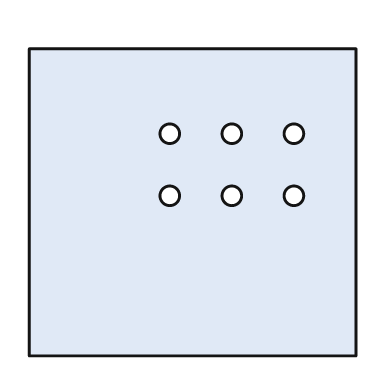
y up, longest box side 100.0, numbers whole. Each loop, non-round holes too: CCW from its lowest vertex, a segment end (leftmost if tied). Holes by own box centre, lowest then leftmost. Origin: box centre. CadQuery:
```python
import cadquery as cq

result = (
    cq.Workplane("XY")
    .moveTo(-50.0, -47.0)
    .lineTo(50.0, -47.0)
    .lineTo(50.0, 47.0)
    .lineTo(-50.0, 47.0)
    .close()
    .moveTo(-7.0, 2.0)
    .circle(3.0)
    .moveTo(12.0, 2.0)
    .circle(3.0)
    .moveTo(31.0, 2.0)
    .circle(3.0)
    .moveTo(-7.0, 21.0)
    .circle(3.0)
    .moveTo(12.0, 21.0)
    .circle(3.0)
    .moveTo(31.0, 21.0)
    .circle(3.0)
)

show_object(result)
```